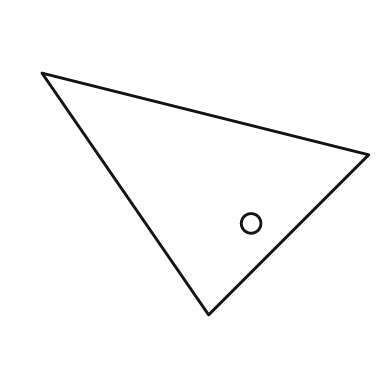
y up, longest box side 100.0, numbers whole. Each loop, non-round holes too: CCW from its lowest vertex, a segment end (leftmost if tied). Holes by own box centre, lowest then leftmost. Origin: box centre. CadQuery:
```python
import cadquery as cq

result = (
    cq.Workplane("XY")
    .moveTo(1.0, -37.0)
    .lineTo(50.0, 12.0)
    .lineTo(-50.0, 37.0)
    .close()
    .moveTo(14.0, -9.0)
    .circle(3.0)
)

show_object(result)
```